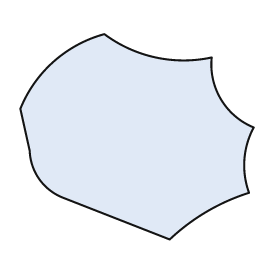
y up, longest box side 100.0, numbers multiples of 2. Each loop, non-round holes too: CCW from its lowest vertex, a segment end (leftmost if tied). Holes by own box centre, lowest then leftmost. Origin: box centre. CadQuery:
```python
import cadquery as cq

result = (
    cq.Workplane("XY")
    .moveTo(14.0, -44.0)
    .threePointArc((30.0, -32.0), (48.0, -24.0))
    .threePointArc((46.0, -10.0), (50.0, 4.0))
    .threePointArc((36.0, 16.0), (32.0, 34.0))
    .threePointArc((8.0, 34.0), (-14.0, 44.0))
    .threePointArc((-36.0, 32.0), (-50.0, 12.0))
    .lineTo(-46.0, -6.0)
    .threePointArc((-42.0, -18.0), (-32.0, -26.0))
    .close()
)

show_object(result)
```